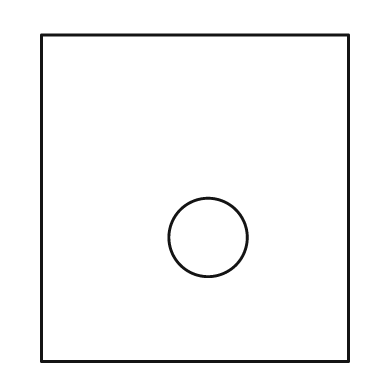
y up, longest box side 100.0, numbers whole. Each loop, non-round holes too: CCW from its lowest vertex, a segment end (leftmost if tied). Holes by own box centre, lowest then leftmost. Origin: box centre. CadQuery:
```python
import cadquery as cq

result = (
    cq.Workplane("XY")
    .moveTo(-47.0, -50.0)
    .lineTo(47.0, -50.0)
    .lineTo(47.0, 50.0)
    .lineTo(-47.0, 50.0)
    .close()
    .moveTo(4.0, -12.0)
    .circle(12.0)
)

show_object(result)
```